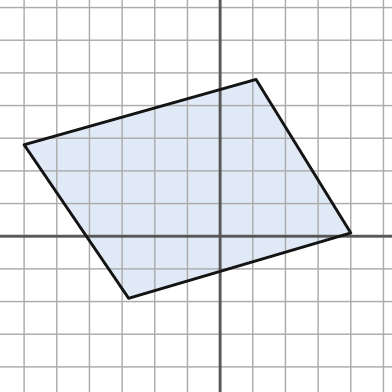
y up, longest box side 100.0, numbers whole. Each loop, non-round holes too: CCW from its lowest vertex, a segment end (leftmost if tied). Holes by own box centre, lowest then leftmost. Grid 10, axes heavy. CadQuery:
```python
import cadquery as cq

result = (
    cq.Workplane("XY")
    .moveTo(-28.0, -19.0)
    .lineTo(40.0, 1.0)
    .lineTo(11.0, 48.0)
    .lineTo(-60.0, 28.0)
    .close()
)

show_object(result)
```